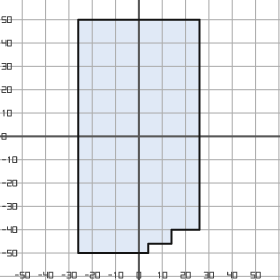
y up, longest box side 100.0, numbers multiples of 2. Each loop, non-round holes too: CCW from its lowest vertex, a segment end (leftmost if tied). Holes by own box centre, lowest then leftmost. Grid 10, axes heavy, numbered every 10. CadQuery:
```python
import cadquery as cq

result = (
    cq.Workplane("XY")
    .moveTo(-26.0, -50.0)
    .lineTo(4.0, -50.0)
    .lineTo(4.0, -46.0)
    .lineTo(14.0, -46.0)
    .lineTo(14.0, -40.0)
    .lineTo(26.0, -40.0)
    .lineTo(26.0, 50.0)
    .lineTo(-26.0, 50.0)
    .close()
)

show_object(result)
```